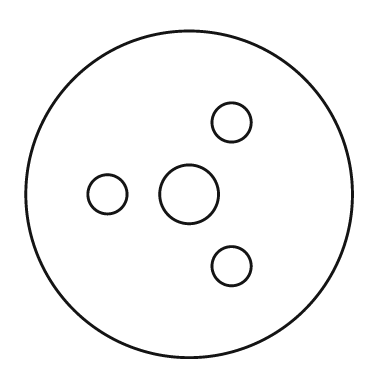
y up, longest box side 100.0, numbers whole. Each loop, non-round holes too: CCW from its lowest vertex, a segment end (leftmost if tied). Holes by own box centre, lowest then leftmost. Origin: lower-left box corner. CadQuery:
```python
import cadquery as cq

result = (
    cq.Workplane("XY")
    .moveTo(50.0, 50.0)
    .circle(50.0)
    .moveTo(63.0, 28.0)
    .circle(6.0)
    .moveTo(25.0, 50.0)
    .circle(6.0)
    .moveTo(50.0, 50.0)
    .circle(9.0)
    .moveTo(63.0, 72.0)
    .circle(6.0)
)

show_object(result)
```